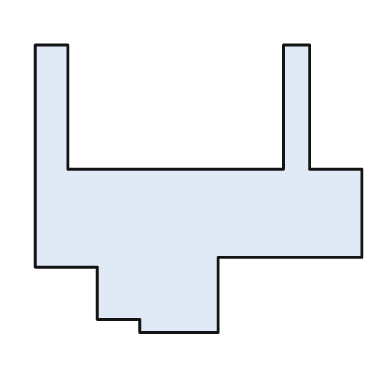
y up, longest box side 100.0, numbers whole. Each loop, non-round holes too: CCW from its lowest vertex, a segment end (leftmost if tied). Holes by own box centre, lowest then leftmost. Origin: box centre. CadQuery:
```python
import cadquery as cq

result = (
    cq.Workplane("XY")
    .moveTo(-18.0, -44.0)
    .lineTo(6.0, -44.0)
    .lineTo(6.0, -21.0)
    .lineTo(50.0, -21.0)
    .lineTo(50.0, 6.0)
    .lineTo(34.0, 6.0)
    .lineTo(34.0, 44.0)
    .lineTo(26.0, 44.0)
    .lineTo(26.0, 6.0)
    .lineTo(-40.0, 6.0)
    .lineTo(-40.0, 44.0)
    .lineTo(-50.0, 44.0)
    .lineTo(-50.0, -24.0)
    .lineTo(-31.0, -24.0)
    .lineTo(-31.0, -40.0)
    .lineTo(-18.0, -40.0)
    .close()
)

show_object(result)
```